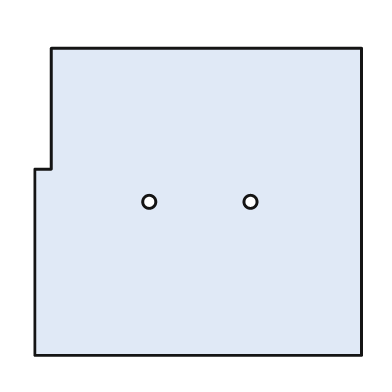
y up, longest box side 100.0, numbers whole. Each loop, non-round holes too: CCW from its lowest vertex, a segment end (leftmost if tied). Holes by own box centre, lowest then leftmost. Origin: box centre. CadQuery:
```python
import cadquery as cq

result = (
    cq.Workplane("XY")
    .moveTo(-50.0, -47.0)
    .lineTo(50.0, -47.0)
    .lineTo(50.0, 47.0)
    .lineTo(-45.0, 47.0)
    .lineTo(-45.0, 10.0)
    .lineTo(-50.0, 10.0)
    .close()
    .moveTo(-15.0, 0.0)
    .circle(2.0)
    .moveTo(16.0, 0.0)
    .circle(2.0)
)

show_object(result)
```